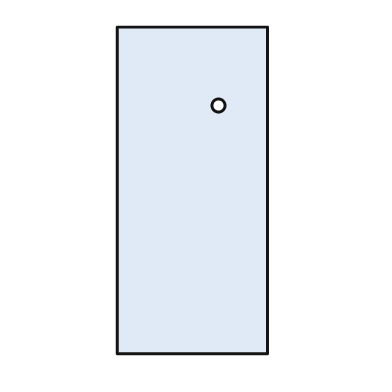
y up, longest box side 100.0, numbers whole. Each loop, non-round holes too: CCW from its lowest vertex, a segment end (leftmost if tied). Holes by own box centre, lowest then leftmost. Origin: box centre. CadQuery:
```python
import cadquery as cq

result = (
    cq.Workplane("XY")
    .moveTo(-23.0, -50.0)
    .lineTo(23.0, -50.0)
    .lineTo(23.0, 50.0)
    .lineTo(-23.0, 50.0)
    .close()
    .moveTo(8.0, 26.0)
    .circle(2.0)
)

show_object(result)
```